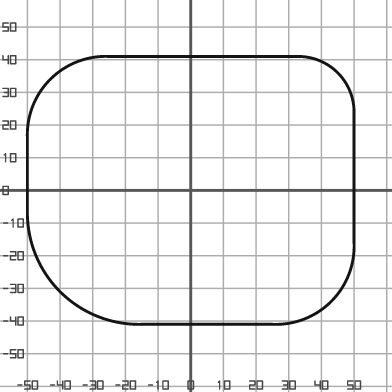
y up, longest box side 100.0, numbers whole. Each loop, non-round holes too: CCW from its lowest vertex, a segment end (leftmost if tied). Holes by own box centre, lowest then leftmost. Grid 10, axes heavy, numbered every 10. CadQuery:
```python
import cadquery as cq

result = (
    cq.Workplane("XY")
    .moveTo(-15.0, -41.0)
    .lineTo(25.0, -41.0)
    .threePointArc((43.0, -34.0), (50.0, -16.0))
    .lineTo(50.0, 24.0)
    .threePointArc((45.0, 36.0), (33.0, 41.0))
    .lineTo(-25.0, 41.0)
    .threePointArc((-43.0, 34.0), (-50.0, 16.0))
    .lineTo(-50.0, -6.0)
    .threePointArc((-40.0, -31.0), (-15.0, -41.0))
    .close()
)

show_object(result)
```